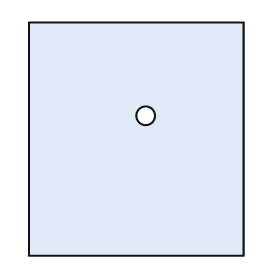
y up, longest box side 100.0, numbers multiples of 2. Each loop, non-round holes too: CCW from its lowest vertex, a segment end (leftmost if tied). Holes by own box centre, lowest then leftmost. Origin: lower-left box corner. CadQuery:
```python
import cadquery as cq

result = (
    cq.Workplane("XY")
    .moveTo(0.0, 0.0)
    .lineTo(92.0, 0.0)
    .lineTo(92.0, 100.0)
    .lineTo(0.0, 100.0)
    .close()
    .moveTo(50.0, 60.0)
    .circle(4.0)
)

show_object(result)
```